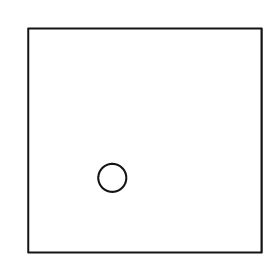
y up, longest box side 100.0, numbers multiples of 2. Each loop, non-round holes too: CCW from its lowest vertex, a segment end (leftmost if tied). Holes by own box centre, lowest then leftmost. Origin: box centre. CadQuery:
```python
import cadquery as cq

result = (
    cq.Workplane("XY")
    .moveTo(-50.0, -48.0)
    .lineTo(50.0, -48.0)
    .lineTo(50.0, 48.0)
    .lineTo(-50.0, 48.0)
    .close()
    .moveTo(-14.0, -16.0)
    .circle(6.0)
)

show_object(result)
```